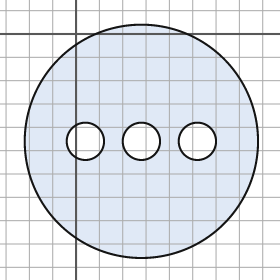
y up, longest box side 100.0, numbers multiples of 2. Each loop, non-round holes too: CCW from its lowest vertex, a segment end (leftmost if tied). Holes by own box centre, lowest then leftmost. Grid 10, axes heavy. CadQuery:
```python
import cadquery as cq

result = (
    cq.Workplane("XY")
    .moveTo(28.0, -46.0)
    .circle(50.0)
    .moveTo(4.0, -46.0)
    .circle(8.0)
    .moveTo(28.0, -46.0)
    .circle(8.0)
    .moveTo(52.0, -46.0)
    .circle(8.0)
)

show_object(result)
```